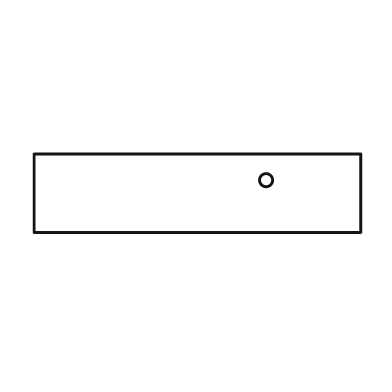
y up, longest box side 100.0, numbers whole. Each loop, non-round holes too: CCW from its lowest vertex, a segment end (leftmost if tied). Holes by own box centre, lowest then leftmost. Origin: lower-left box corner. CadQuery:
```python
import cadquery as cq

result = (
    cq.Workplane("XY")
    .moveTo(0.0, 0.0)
    .lineTo(100.0, 0.0)
    .lineTo(100.0, 24.0)
    .lineTo(0.0, 24.0)
    .close()
    .moveTo(71.0, 16.0)
    .circle(2.0)
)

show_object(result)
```